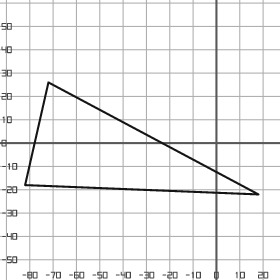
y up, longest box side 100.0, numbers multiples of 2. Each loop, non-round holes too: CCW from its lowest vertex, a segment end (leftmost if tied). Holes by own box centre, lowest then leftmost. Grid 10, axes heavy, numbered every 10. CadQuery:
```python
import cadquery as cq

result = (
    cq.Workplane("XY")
    .moveTo(18.0, -22.0)
    .lineTo(-72.0, 26.0)
    .lineTo(-82.0, -18.0)
    .close()
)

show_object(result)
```